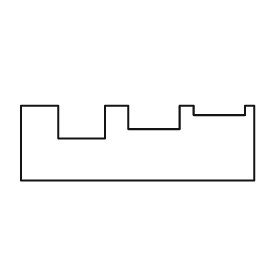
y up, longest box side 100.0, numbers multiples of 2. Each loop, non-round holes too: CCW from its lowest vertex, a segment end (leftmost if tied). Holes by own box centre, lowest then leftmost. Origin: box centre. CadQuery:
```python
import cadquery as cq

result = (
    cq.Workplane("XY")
    .moveTo(-50.0, -16.0)
    .lineTo(50.0, -16.0)
    .lineTo(50.0, 16.0)
    .lineTo(46.0, 16.0)
    .lineTo(46.0, 12.0)
    .lineTo(24.0, 12.0)
    .lineTo(24.0, 16.0)
    .lineTo(18.0, 16.0)
    .lineTo(18.0, 6.0)
    .lineTo(-4.0, 6.0)
    .lineTo(-4.0, 16.0)
    .lineTo(-14.0, 16.0)
    .lineTo(-14.0, 2.0)
    .lineTo(-34.0, 2.0)
    .lineTo(-34.0, 16.0)
    .lineTo(-50.0, 16.0)
    .close()
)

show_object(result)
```